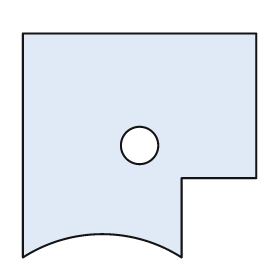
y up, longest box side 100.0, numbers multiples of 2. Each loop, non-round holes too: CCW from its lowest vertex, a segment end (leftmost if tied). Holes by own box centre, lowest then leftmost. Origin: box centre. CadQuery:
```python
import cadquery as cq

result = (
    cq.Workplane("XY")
    .moveTo(-50.0, -48.0)
    .threePointArc((-16.0, -38.0), (18.0, -48.0))
    .lineTo(18.0, -14.0)
    .lineTo(50.0, -14.0)
    .lineTo(50.0, 48.0)
    .lineTo(-50.0, 48.0)
    .close()
    .moveTo(0.0, 0.0)
    .circle(8.0)
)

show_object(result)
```